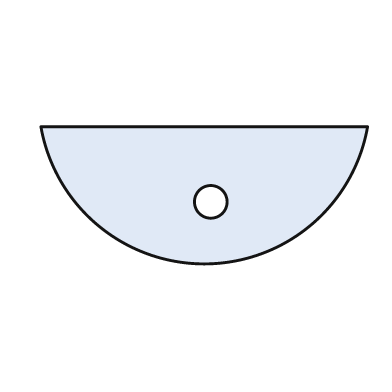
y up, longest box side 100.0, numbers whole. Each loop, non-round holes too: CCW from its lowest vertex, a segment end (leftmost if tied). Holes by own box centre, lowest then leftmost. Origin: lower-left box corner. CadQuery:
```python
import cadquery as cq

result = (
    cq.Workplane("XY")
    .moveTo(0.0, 42.0)
    .threePointArc((50.0, 0.0), (100.0, 42.0))
    .close()
    .moveTo(52.0, 19.0)
    .circle(5.0)
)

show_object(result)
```